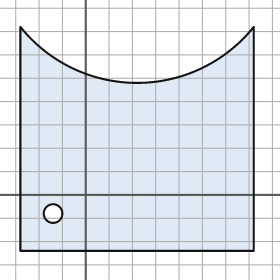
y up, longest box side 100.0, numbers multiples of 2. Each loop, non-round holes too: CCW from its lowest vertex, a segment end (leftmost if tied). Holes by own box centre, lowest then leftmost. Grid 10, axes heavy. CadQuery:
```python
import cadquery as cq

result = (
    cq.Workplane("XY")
    .moveTo(-28.0, -24.0)
    .lineTo(72.0, -24.0)
    .lineTo(72.0, 72.0)
    .threePointArc((22.0, 48.0), (-28.0, 72.0))
    .close()
    .moveTo(-14.0, -8.0)
    .circle(4.0)
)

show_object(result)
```